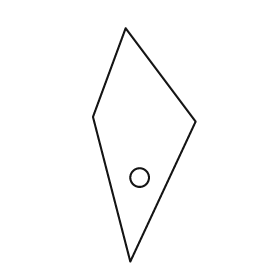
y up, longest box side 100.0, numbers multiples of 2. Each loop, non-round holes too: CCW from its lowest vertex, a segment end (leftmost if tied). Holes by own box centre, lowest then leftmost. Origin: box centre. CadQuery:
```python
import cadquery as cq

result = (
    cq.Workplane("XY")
    .moveTo(-6.0, -50.0)
    .lineTo(22.0, 10.0)
    .lineTo(-8.0, 50.0)
    .lineTo(-22.0, 12.0)
    .close()
    .moveTo(-2.0, -14.0)
    .circle(4.0)
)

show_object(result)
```